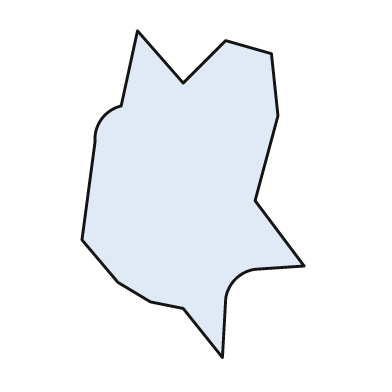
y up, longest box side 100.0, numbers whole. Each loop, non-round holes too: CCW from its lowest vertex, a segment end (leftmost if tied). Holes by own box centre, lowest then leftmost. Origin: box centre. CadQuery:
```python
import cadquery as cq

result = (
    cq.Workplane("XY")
    .moveTo(9.0, -50.0)
    .lineTo(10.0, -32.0)
    .threePointArc((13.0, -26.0), (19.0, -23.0))
    .lineTo(34.0, -22.0)
    .lineTo(19.0, -2.0)
    .lineTo(26.0, 24.0)
    .lineTo(24.0, 43.0)
    .lineTo(10.0, 47.0)
    .lineTo(-3.0, 34.0)
    .lineTo(-17.0, 50.0)
    .lineTo(-22.0, 27.0)
    .threePointArc((-28.0, 23.0), (-30.0, 16.0))
    .lineTo(-34.0, -14.0)
    .lineTo(-23.0, -27.0)
    .lineTo(-13.0, -33.0)
    .lineTo(-3.0, -35.0)
    .close()
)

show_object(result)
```